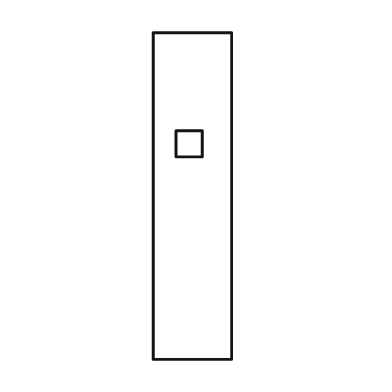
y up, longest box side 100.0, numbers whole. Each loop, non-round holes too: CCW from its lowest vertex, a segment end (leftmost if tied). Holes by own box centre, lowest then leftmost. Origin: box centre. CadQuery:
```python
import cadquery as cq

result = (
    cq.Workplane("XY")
    .moveTo(-12.0, -50.0)
    .lineTo(12.0, -50.0)
    .lineTo(12.0, 50.0)
    .lineTo(-12.0, 50.0)
    .close()
    .moveTo(-5.0, 12.0)
    .lineTo(3.0, 12.0)
    .lineTo(3.0, 20.0)
    .lineTo(-5.0, 20.0)
    .close()
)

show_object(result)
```